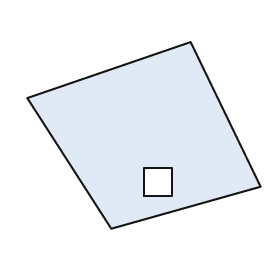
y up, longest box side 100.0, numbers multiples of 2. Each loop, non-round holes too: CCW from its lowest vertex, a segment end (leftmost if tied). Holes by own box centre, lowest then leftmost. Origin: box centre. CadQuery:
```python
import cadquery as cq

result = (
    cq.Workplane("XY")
    .moveTo(-14.0, -40.0)
    .lineTo(50.0, -22.0)
    .lineTo(20.0, 40.0)
    .lineTo(-50.0, 16.0)
    .close()
    .moveTo(0.0, -26.0)
    .lineTo(12.0, -26.0)
    .lineTo(12.0, -14.0)
    .lineTo(0.0, -14.0)
    .close()
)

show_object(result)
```